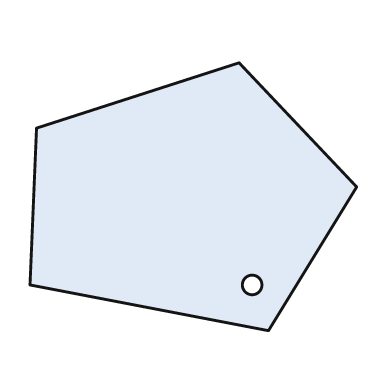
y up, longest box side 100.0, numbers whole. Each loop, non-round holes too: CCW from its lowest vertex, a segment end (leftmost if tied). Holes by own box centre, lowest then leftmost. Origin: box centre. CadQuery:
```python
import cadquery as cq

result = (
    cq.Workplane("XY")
    .moveTo(23.0, -41.0)
    .lineTo(50.0, 3.0)
    .lineTo(14.0, 41.0)
    .lineTo(-48.0, 21.0)
    .lineTo(-50.0, -27.0)
    .close()
    .moveTo(18.0, -27.0)
    .circle(3.0)
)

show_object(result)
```